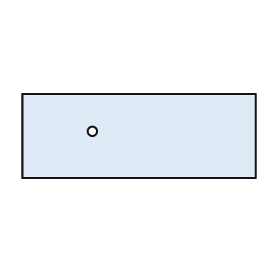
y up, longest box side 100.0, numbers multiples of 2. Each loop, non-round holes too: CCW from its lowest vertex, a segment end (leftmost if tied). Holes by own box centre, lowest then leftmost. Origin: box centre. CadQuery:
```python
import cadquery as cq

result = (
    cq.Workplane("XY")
    .moveTo(-50.0, -18.0)
    .lineTo(50.0, -18.0)
    .lineTo(50.0, 18.0)
    .lineTo(-50.0, 18.0)
    .close()
    .moveTo(-20.0, 2.0)
    .circle(2.0)
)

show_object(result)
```